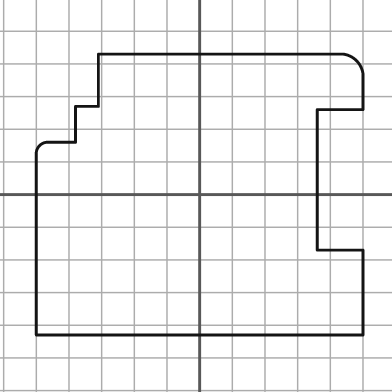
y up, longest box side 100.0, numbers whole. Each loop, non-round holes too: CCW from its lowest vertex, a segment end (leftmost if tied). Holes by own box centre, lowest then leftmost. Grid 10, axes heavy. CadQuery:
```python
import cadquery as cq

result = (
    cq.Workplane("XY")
    .moveTo(-50.0, -43.0)
    .lineTo(50.0, -43.0)
    .lineTo(50.0, -17.0)
    .lineTo(36.0, -17.0)
    .lineTo(36.0, 26.0)
    .lineTo(50.0, 26.0)
    .lineTo(50.0, 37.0)
    .threePointArc((48.0, 41.0), (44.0, 43.0))
    .lineTo(-31.0, 43.0)
    .lineTo(-31.0, 27.0)
    .lineTo(-38.0, 27.0)
    .lineTo(-38.0, 16.0)
    .lineTo(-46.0, 16.0)
    .threePointArc((-49.0, 15.0), (-50.0, 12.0))
    .close()
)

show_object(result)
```